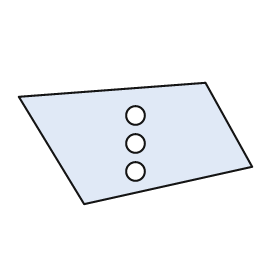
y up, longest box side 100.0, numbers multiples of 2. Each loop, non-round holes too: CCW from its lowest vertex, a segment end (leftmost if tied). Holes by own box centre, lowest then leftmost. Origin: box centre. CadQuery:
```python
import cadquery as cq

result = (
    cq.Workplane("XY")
    .moveTo(-22.0, -26.0)
    .lineTo(50.0, -10.0)
    .lineTo(30.0, 26.0)
    .lineTo(-50.0, 20.0)
    .close()
    .moveTo(0.0, -12.0)
    .circle(4.0)
    .moveTo(0.0, 0.0)
    .circle(4.0)
    .moveTo(0.0, 12.0)
    .circle(4.0)
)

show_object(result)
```